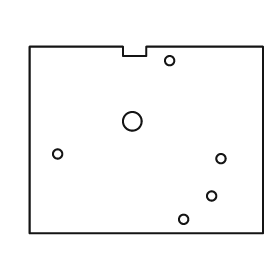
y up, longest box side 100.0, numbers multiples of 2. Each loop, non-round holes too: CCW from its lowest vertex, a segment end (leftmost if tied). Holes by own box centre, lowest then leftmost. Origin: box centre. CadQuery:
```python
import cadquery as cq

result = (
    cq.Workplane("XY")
    .moveTo(-50.0, -40.0)
    .lineTo(50.0, -40.0)
    .lineTo(50.0, 40.0)
    .lineTo(0.0, 40.0)
    .lineTo(0.0, 36.0)
    .lineTo(-10.0, 36.0)
    .lineTo(-10.0, 40.0)
    .lineTo(-50.0, 40.0)
    .close()
    .moveTo(16.0, -34.0)
    .circle(2.0)
    .moveTo(28.0, -24.0)
    .circle(2.0)
    .moveTo(32.0, -8.0)
    .circle(2.0)
    .moveTo(-38.0, -6.0)
    .circle(2.0)
    .moveTo(-6.0, 8.0)
    .circle(4.0)
    .moveTo(10.0, 34.0)
    .circle(2.0)
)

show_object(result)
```